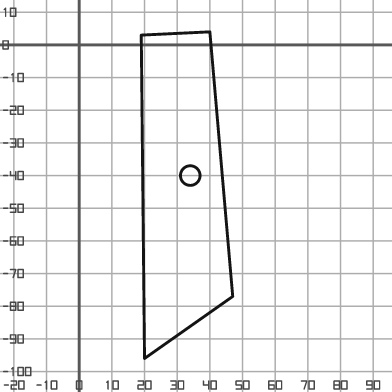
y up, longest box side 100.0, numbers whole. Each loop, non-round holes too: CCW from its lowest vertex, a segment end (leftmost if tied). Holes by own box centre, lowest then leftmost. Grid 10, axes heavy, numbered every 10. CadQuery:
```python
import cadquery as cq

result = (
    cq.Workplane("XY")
    .moveTo(20.0, -96.0)
    .lineTo(47.0, -77.0)
    .lineTo(40.0, 4.0)
    .lineTo(19.0, 3.0)
    .close()
    .moveTo(34.0, -40.0)
    .circle(3.0)
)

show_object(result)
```